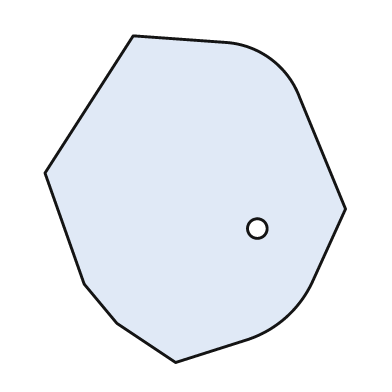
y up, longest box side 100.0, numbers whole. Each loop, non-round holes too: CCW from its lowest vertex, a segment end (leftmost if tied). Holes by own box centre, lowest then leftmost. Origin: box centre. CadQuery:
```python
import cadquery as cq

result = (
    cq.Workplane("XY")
    .moveTo(-6.0, -50.0)
    .lineTo(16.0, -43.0)
    .threePointArc((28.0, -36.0), (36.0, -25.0))
    .lineTo(46.0, -3.0)
    .lineTo(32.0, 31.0)
    .threePointArc((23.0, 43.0), (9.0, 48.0))
    .lineTo(-19.0, 50.0)
    .lineTo(-46.0, 8.0)
    .lineTo(-34.0, -26.0)
    .lineTo(-24.0, -38.0)
    .close()
    .moveTo(19.0, -9.0)
    .circle(3.0)
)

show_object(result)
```